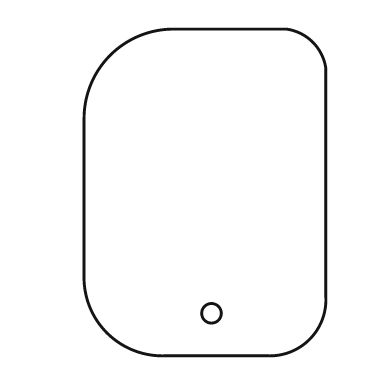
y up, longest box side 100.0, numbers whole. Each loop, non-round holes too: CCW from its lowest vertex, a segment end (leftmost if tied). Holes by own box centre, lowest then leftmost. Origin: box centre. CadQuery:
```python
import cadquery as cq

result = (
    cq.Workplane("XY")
    .moveTo(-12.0, -50.0)
    .lineTo(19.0, -50.0)
    .threePointArc((32.0, -45.0), (37.0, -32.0))
    .lineTo(37.0, 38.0)
    .threePointArc((33.0, 46.0), (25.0, 50.0))
    .lineTo(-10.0, 50.0)
    .threePointArc((-29.0, 42.0), (-37.0, 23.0))
    .lineTo(-37.0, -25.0)
    .threePointArc((-30.0, -43.0), (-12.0, -50.0))
    .close()
    .moveTo(2.0, -37.0)
    .circle(3.0)
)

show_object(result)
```